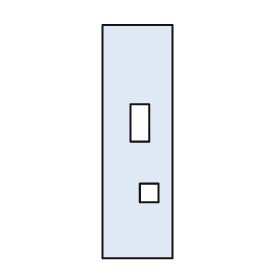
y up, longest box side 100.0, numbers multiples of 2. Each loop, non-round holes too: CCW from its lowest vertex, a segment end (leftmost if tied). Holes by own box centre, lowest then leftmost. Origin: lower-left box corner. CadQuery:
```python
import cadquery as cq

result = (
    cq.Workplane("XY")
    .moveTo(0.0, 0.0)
    .lineTo(30.0, 0.0)
    .lineTo(30.0, 100.0)
    .lineTo(0.0, 100.0)
    .close()
    .moveTo(16.0, 24.0)
    .lineTo(24.0, 24.0)
    .lineTo(24.0, 32.0)
    .lineTo(16.0, 32.0)
    .close()
    .moveTo(12.0, 50.0)
    .lineTo(20.0, 50.0)
    .lineTo(20.0, 66.0)
    .lineTo(12.0, 66.0)
    .close()
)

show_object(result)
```